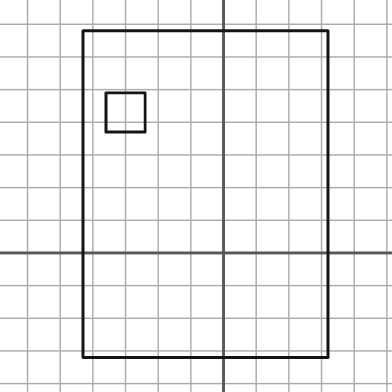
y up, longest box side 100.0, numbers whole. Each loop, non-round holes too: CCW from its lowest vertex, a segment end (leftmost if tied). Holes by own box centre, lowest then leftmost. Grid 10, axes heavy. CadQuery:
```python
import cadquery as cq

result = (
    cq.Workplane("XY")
    .moveTo(-43.0, -32.0)
    .lineTo(32.0, -32.0)
    .lineTo(32.0, 68.0)
    .lineTo(-43.0, 68.0)
    .close()
    .moveTo(-36.0, 37.0)
    .lineTo(-24.0, 37.0)
    .lineTo(-24.0, 49.0)
    .lineTo(-36.0, 49.0)
    .close()
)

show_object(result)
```